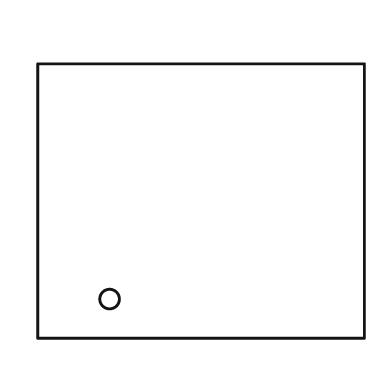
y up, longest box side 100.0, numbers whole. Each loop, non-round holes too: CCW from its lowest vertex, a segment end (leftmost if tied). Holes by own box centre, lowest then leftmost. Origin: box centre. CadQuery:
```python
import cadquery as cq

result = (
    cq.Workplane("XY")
    .moveTo(-50.0, -42.0)
    .lineTo(50.0, -42.0)
    .lineTo(50.0, 42.0)
    .lineTo(-50.0, 42.0)
    .close()
    .moveTo(-28.0, -30.0)
    .circle(3.0)
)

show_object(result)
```